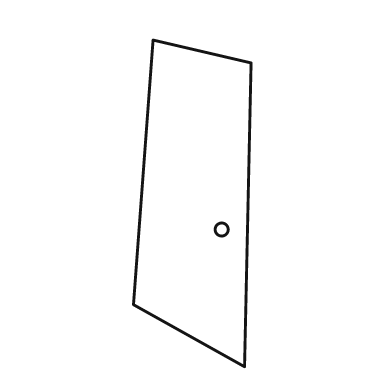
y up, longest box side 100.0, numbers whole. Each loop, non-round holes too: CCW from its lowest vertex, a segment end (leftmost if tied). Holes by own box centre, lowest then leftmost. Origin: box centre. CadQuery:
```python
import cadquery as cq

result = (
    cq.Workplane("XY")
    .moveTo(16.0, -50.0)
    .lineTo(18.0, 43.0)
    .lineTo(-12.0, 50.0)
    .lineTo(-18.0, -31.0)
    .close()
    .moveTo(9.0, -8.0)
    .circle(2.0)
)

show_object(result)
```